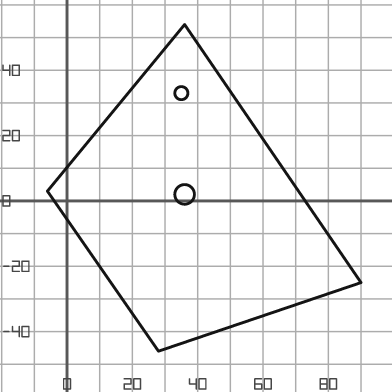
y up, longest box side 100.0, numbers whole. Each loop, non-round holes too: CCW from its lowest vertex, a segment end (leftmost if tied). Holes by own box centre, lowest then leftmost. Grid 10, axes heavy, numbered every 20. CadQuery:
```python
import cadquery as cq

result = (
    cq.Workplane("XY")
    .moveTo(28.0, -46.0)
    .lineTo(90.0, -25.0)
    .lineTo(36.0, 54.0)
    .lineTo(-6.0, 3.0)
    .close()
    .moveTo(36.0, 2.0)
    .circle(3.0)
    .moveTo(35.0, 33.0)
    .circle(2.0)
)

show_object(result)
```